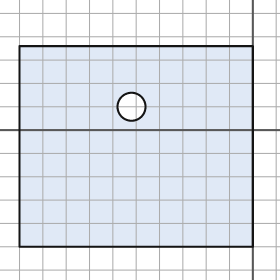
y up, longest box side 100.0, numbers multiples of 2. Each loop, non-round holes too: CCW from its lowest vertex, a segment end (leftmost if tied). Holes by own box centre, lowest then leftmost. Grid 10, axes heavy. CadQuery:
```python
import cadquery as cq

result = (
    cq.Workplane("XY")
    .moveTo(-100.0, -50.0)
    .lineTo(0.0, -50.0)
    .lineTo(0.0, 36.0)
    .lineTo(-100.0, 36.0)
    .close()
    .moveTo(-52.0, 10.0)
    .circle(6.0)
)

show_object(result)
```